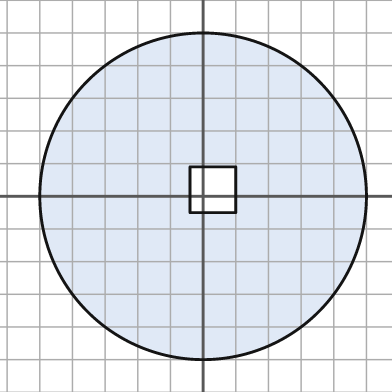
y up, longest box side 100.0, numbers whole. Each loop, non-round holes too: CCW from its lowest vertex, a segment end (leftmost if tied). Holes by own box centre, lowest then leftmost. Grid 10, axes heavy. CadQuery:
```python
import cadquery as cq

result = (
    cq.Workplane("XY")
    .moveTo(0.0, 0.0)
    .circle(50.0)
    .moveTo(-4.0, -5.0)
    .lineTo(10.0, -5.0)
    .lineTo(10.0, 9.0)
    .lineTo(-4.0, 9.0)
    .close()
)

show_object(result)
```